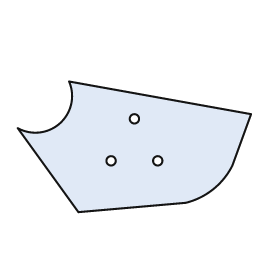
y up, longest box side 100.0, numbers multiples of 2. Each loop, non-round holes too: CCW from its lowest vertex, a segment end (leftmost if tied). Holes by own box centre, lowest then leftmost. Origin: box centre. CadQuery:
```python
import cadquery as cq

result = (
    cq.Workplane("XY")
    .moveTo(-24.0, -28.0)
    .lineTo(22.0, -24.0)
    .threePointArc((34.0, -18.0), (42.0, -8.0))
    .lineTo(50.0, 14.0)
    .lineTo(-28.0, 28.0)
    .threePointArc((-32.0, 10.0), (-50.0, 8.0))
    .close()
    .moveTo(-10.0, -6.0)
    .circle(2.0)
    .moveTo(10.0, -6.0)
    .circle(2.0)
    .moveTo(0.0, 12.0)
    .circle(2.0)
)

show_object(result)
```